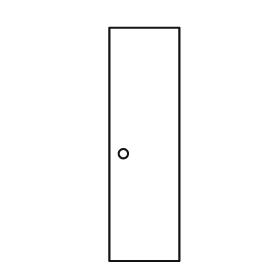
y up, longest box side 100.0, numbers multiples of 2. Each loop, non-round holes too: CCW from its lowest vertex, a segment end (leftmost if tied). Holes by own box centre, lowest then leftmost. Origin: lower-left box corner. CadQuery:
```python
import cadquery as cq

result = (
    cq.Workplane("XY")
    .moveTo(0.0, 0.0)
    .lineTo(30.0, 0.0)
    .lineTo(30.0, 100.0)
    .lineTo(0.0, 100.0)
    .close()
    .moveTo(6.0, 46.0)
    .circle(2.0)
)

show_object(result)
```